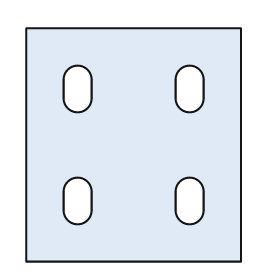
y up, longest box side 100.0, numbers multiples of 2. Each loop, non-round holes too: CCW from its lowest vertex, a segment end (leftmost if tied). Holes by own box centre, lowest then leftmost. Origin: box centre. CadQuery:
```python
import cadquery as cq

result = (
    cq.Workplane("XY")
    .moveTo(-46.0, -50.0)
    .lineTo(46.0, -50.0)
    .lineTo(46.0, 50.0)
    .lineTo(-46.0, 50.0)
    .close()
    .moveTo(-30.0, -28.0)
    .threePointArc((-24.0, -34.0), (-18.0, -28.0))
    .lineTo(-18.0, -20.0)
    .threePointArc((-24.0, -14.0), (-30.0, -20.0))
    .close()
    .moveTo(18.0, -28.0)
    .threePointArc((24.0, -34.0), (30.0, -28.0))
    .lineTo(30.0, -20.0)
    .threePointArc((24.0, -14.0), (18.0, -20.0))
    .close()
    .moveTo(-30.0, 20.0)
    .threePointArc((-24.0, 14.0), (-18.0, 20.0))
    .lineTo(-18.0, 28.0)
    .threePointArc((-24.0, 34.0), (-30.0, 28.0))
    .close()
    .moveTo(18.0, 20.0)
    .threePointArc((24.0, 14.0), (30.0, 20.0))
    .lineTo(30.0, 28.0)
    .threePointArc((24.0, 34.0), (18.0, 28.0))
    .close()
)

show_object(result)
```